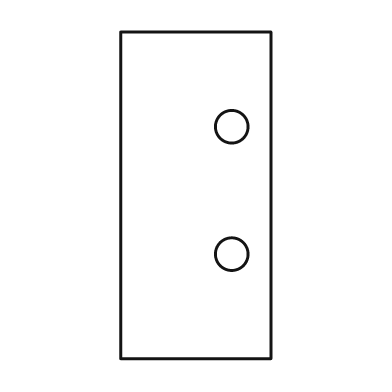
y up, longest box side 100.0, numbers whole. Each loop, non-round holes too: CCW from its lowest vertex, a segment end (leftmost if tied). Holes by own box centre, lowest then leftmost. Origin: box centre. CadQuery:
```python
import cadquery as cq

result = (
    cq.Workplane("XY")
    .moveTo(-23.0, -50.0)
    .lineTo(23.0, -50.0)
    .lineTo(23.0, 50.0)
    .lineTo(-23.0, 50.0)
    .close()
    .moveTo(11.0, -18.0)
    .circle(5.0)
    .moveTo(11.0, 21.0)
    .circle(5.0)
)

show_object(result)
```